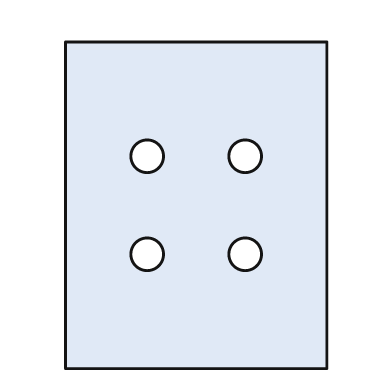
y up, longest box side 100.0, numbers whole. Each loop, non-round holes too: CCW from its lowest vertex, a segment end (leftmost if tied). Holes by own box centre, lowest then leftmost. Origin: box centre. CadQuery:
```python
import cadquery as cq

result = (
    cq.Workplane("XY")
    .moveTo(-40.0, -50.0)
    .lineTo(40.0, -50.0)
    .lineTo(40.0, 50.0)
    .lineTo(-40.0, 50.0)
    .close()
    .moveTo(-15.0, -15.0)
    .circle(5.0)
    .moveTo(15.0, -15.0)
    .circle(5.0)
    .moveTo(-15.0, 15.0)
    .circle(5.0)
    .moveTo(15.0, 15.0)
    .circle(5.0)
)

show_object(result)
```